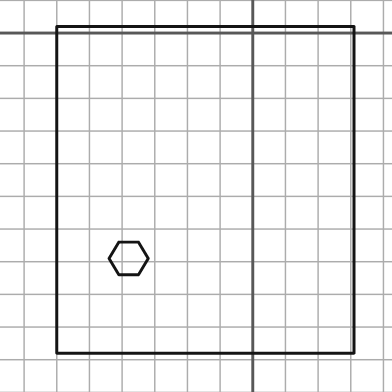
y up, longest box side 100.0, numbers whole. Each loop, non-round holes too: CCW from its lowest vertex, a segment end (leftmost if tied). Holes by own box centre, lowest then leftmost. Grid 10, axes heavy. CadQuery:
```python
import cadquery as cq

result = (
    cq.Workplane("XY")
    .moveTo(-60.0, -98.0)
    .lineTo(31.0, -98.0)
    .lineTo(31.0, 2.0)
    .lineTo(-60.0, 2.0)
    .close()
    .moveTo(-41.0, -74.0)
    .lineTo(-35.0, -74.0)
    .lineTo(-32.0, -69.0)
    .lineTo(-35.0, -64.0)
    .lineTo(-41.0, -64.0)
    .lineTo(-44.0, -69.0)
    .close()
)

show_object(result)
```